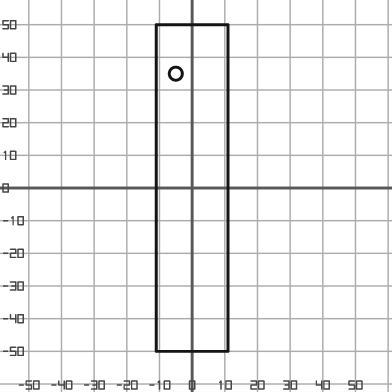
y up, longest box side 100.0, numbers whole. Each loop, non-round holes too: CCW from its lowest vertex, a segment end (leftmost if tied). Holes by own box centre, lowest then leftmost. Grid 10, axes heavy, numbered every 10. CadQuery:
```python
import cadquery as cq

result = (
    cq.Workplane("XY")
    .moveTo(-11.0, -50.0)
    .lineTo(11.0, -50.0)
    .lineTo(11.0, 50.0)
    .lineTo(-11.0, 50.0)
    .close()
    .moveTo(-5.0, 35.0)
    .circle(2.0)
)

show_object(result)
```